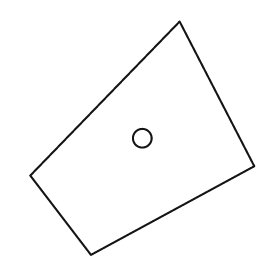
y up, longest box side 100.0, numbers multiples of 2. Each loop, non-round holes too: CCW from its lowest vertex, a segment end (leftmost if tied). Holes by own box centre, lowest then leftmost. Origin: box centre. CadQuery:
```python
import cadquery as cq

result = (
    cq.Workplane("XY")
    .moveTo(-22.0, -50.0)
    .lineTo(48.0, -12.0)
    .lineTo(16.0, 50.0)
    .lineTo(-48.0, -16.0)
    .close()
    .moveTo(0.0, 0.0)
    .circle(4.0)
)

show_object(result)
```